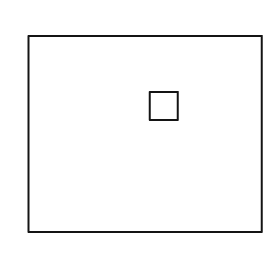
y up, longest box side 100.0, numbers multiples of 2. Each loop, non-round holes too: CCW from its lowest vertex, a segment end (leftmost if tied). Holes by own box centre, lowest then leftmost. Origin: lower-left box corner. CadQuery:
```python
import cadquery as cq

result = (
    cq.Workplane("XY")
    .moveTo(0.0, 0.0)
    .lineTo(100.0, 0.0)
    .lineTo(100.0, 84.0)
    .lineTo(0.0, 84.0)
    .close()
    .moveTo(52.0, 48.0)
    .lineTo(64.0, 48.0)
    .lineTo(64.0, 60.0)
    .lineTo(52.0, 60.0)
    .close()
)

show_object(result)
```